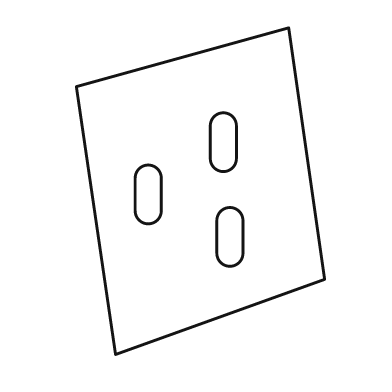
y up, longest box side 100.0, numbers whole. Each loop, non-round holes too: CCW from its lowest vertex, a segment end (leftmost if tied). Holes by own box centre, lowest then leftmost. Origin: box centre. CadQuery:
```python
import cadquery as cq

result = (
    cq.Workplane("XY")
    .moveTo(-26.0, -50.0)
    .lineTo(38.0, -27.0)
    .lineTo(27.0, 50.0)
    .lineTo(-38.0, 32.0)
    .close()
    .moveTo(5.0, -19.0)
    .threePointArc((9.0, -23.0), (13.0, -19.0))
    .lineTo(13.0, -9.0)
    .threePointArc((9.0, -5.0), (5.0, -9.0))
    .close()
    .moveTo(-20.0, -6.0)
    .threePointArc((-16.0, -10.0), (-12.0, -6.0))
    .lineTo(-12.0, 4.0)
    .threePointArc((-16.0, 8.0), (-20.0, 4.0))
    .close()
    .moveTo(3.0, 10.0)
    .threePointArc((7.0, 6.0), (11.0, 10.0))
    .lineTo(11.0, 20.0)
    .threePointArc((7.0, 24.0), (3.0, 20.0))
    .close()
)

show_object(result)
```